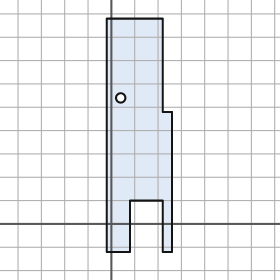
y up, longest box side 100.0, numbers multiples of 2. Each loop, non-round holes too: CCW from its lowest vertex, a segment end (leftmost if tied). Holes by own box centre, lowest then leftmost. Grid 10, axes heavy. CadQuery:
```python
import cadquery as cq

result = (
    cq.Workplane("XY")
    .moveTo(-2.0, -12.0)
    .lineTo(8.0, -12.0)
    .lineTo(8.0, 10.0)
    .lineTo(22.0, 10.0)
    .lineTo(22.0, -12.0)
    .lineTo(26.0, -12.0)
    .lineTo(26.0, 48.0)
    .lineTo(22.0, 48.0)
    .lineTo(22.0, 88.0)
    .lineTo(-2.0, 88.0)
    .close()
    .moveTo(4.0, 54.0)
    .circle(2.0)
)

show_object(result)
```